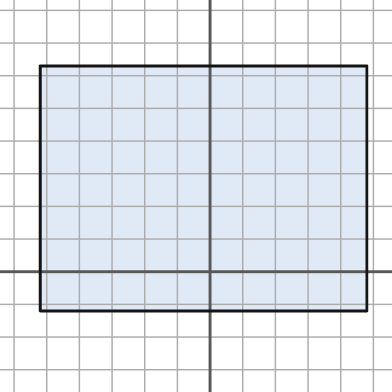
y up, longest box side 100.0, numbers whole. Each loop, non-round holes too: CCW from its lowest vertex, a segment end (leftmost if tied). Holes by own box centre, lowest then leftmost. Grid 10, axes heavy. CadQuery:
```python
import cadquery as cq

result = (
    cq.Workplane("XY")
    .moveTo(-52.0, -12.0)
    .lineTo(48.0, -12.0)
    .lineTo(48.0, 63.0)
    .lineTo(-52.0, 63.0)
    .close()
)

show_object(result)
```